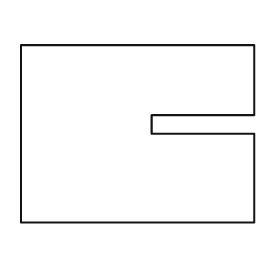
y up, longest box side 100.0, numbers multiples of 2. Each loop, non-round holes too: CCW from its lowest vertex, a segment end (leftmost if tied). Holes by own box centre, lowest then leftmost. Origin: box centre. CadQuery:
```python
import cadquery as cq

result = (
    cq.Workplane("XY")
    .moveTo(-50.0, -38.0)
    .lineTo(50.0, -38.0)
    .lineTo(50.0, 0.0)
    .lineTo(6.0, 0.0)
    .lineTo(6.0, 8.0)
    .lineTo(50.0, 8.0)
    .lineTo(50.0, 38.0)
    .lineTo(-50.0, 38.0)
    .close()
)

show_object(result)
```